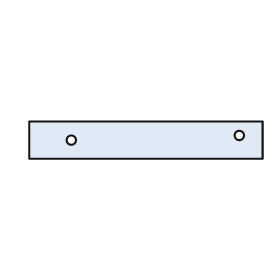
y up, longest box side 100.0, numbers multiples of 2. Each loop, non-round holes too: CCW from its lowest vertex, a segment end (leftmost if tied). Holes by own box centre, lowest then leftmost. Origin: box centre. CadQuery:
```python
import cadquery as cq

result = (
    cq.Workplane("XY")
    .moveTo(-50.0, -8.0)
    .lineTo(50.0, -8.0)
    .lineTo(50.0, 8.0)
    .lineTo(-50.0, 8.0)
    .close()
    .moveTo(-32.0, 0.0)
    .circle(2.0)
    .moveTo(40.0, 2.0)
    .circle(2.0)
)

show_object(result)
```